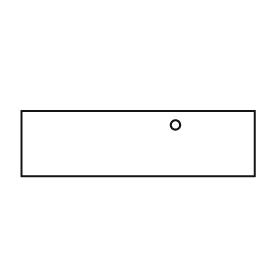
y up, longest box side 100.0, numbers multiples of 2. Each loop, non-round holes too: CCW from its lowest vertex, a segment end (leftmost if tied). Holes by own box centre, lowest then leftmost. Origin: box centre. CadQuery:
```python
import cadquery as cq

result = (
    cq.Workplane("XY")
    .moveTo(-50.0, -14.0)
    .lineTo(50.0, -14.0)
    .lineTo(50.0, 14.0)
    .lineTo(-50.0, 14.0)
    .close()
    .moveTo(16.0, 8.0)
    .circle(2.0)
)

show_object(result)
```